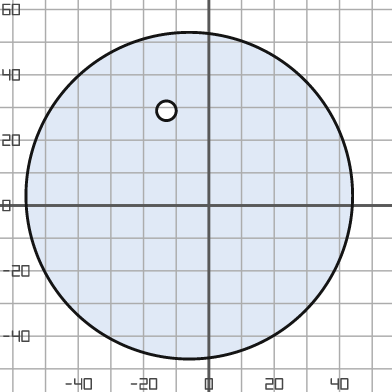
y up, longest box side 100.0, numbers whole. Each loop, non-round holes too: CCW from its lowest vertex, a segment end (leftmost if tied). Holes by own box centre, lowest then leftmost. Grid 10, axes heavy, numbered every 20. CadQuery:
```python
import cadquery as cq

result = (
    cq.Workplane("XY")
    .moveTo(-6.0, 3.0)
    .circle(50.0)
    .moveTo(-13.0, 29.0)
    .circle(3.0)
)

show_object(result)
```